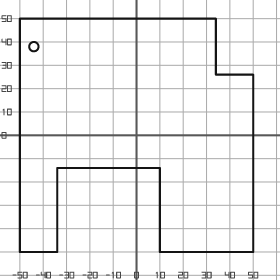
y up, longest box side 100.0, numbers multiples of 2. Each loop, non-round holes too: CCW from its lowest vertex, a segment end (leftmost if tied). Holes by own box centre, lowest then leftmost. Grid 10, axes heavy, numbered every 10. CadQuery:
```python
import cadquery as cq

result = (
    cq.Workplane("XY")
    .moveTo(-50.0, -50.0)
    .lineTo(-34.0, -50.0)
    .lineTo(-34.0, -14.0)
    .lineTo(10.0, -14.0)
    .lineTo(10.0, -50.0)
    .lineTo(50.0, -50.0)
    .lineTo(50.0, 26.0)
    .lineTo(34.0, 26.0)
    .lineTo(34.0, 50.0)
    .lineTo(-50.0, 50.0)
    .close()
    .moveTo(-44.0, 38.0)
    .circle(2.0)
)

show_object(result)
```